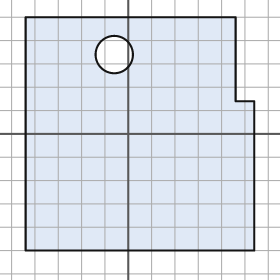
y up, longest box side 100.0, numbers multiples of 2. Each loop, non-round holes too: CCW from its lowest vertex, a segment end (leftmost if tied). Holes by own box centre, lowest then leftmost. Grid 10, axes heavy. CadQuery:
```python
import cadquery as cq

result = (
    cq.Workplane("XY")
    .moveTo(-44.0, -50.0)
    .lineTo(54.0, -50.0)
    .lineTo(54.0, 14.0)
    .lineTo(46.0, 14.0)
    .lineTo(46.0, 50.0)
    .lineTo(-44.0, 50.0)
    .close()
    .moveTo(-6.0, 34.0)
    .circle(8.0)
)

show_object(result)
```